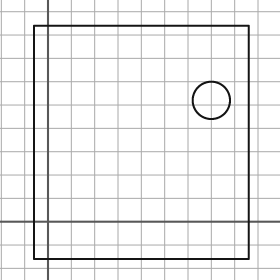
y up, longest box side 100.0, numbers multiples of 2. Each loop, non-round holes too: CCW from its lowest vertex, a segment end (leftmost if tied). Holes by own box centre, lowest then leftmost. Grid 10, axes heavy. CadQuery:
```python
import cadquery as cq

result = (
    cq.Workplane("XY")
    .moveTo(-6.0, -16.0)
    .lineTo(86.0, -16.0)
    .lineTo(86.0, 84.0)
    .lineTo(-6.0, 84.0)
    .close()
    .moveTo(70.0, 52.0)
    .circle(8.0)
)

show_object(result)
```